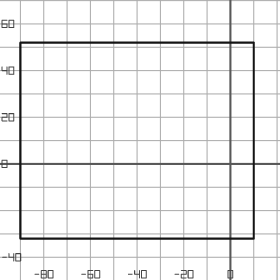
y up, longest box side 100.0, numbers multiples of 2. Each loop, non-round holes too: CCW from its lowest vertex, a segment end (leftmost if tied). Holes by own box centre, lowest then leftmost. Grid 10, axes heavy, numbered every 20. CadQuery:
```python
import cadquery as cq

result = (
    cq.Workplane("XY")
    .moveTo(-90.0, -32.0)
    .lineTo(10.0, -32.0)
    .lineTo(10.0, 52.0)
    .lineTo(-90.0, 52.0)
    .close()
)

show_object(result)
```